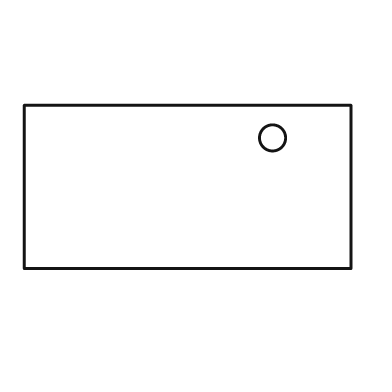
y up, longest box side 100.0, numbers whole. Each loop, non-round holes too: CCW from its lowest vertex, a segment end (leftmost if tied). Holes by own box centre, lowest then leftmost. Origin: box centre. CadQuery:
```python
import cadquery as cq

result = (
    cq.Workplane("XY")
    .moveTo(-50.0, -25.0)
    .lineTo(50.0, -25.0)
    .lineTo(50.0, 25.0)
    .lineTo(-50.0, 25.0)
    .close()
    .moveTo(26.0, 15.0)
    .circle(4.0)
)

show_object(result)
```